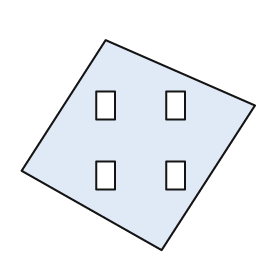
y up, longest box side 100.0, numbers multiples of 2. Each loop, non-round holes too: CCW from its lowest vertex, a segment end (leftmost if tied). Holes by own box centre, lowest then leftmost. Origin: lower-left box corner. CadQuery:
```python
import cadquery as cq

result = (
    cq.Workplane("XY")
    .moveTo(60.0, 0.0)
    .lineTo(100.0, 62.0)
    .lineTo(36.0, 90.0)
    .lineTo(0.0, 34.0)
    .close()
    .moveTo(32.0, 26.0)
    .lineTo(40.0, 26.0)
    .lineTo(40.0, 38.0)
    .lineTo(32.0, 38.0)
    .close()
    .moveTo(62.0, 26.0)
    .lineTo(70.0, 26.0)
    .lineTo(70.0, 38.0)
    .lineTo(62.0, 38.0)
    .close()
    .moveTo(32.0, 56.0)
    .lineTo(40.0, 56.0)
    .lineTo(40.0, 68.0)
    .lineTo(32.0, 68.0)
    .close()
    .moveTo(62.0, 56.0)
    .lineTo(70.0, 56.0)
    .lineTo(70.0, 68.0)
    .lineTo(62.0, 68.0)
    .close()
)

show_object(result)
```